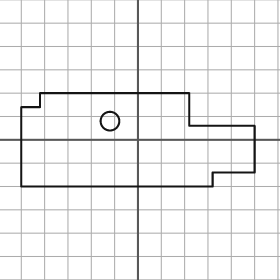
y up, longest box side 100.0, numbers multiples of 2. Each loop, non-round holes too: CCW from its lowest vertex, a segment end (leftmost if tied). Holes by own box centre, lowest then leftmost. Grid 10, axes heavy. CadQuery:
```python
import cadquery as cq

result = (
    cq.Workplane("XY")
    .moveTo(-50.0, -20.0)
    .lineTo(32.0, -20.0)
    .lineTo(32.0, -14.0)
    .lineTo(50.0, -14.0)
    .lineTo(50.0, 6.0)
    .lineTo(22.0, 6.0)
    .lineTo(22.0, 20.0)
    .lineTo(-42.0, 20.0)
    .lineTo(-42.0, 14.0)
    .lineTo(-50.0, 14.0)
    .close()
    .moveTo(-12.0, 8.0)
    .circle(4.0)
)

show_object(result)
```